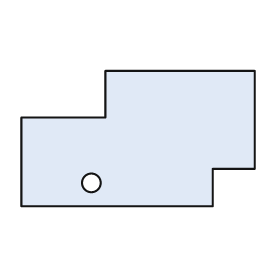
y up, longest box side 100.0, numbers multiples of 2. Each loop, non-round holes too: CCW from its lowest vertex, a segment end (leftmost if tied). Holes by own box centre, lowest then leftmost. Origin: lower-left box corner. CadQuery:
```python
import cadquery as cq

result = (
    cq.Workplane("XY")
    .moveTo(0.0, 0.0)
    .lineTo(82.0, 0.0)
    .lineTo(82.0, 16.0)
    .lineTo(100.0, 16.0)
    .lineTo(100.0, 58.0)
    .lineTo(36.0, 58.0)
    .lineTo(36.0, 38.0)
    .lineTo(0.0, 38.0)
    .close()
    .moveTo(30.0, 10.0)
    .circle(4.0)
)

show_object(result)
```